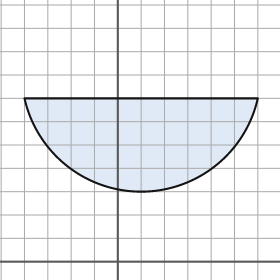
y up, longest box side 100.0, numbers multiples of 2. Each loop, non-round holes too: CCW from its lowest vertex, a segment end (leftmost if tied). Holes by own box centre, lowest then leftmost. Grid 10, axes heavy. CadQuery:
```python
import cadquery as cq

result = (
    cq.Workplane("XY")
    .moveTo(-40.0, 70.0)
    .threePointArc((10.0, 30.0), (60.0, 70.0))
    .close()
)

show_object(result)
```